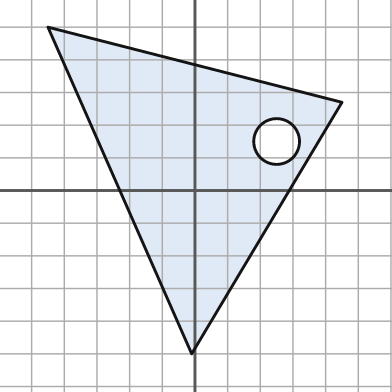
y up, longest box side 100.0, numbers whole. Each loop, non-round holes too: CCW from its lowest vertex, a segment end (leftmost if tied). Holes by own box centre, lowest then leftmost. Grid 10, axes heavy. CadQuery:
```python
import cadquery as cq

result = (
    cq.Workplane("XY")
    .moveTo(-1.0, -50.0)
    .lineTo(45.0, 27.0)
    .lineTo(-45.0, 50.0)
    .close()
    .moveTo(25.0, 15.0)
    .circle(7.0)
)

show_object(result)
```